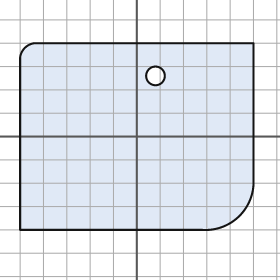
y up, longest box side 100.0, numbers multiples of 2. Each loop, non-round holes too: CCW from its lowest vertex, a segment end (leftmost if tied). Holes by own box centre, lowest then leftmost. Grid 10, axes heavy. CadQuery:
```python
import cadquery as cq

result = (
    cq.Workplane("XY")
    .moveTo(-50.0, -40.0)
    .lineTo(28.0, -40.0)
    .threePointArc((44.0, -34.0), (50.0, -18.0))
    .lineTo(50.0, 40.0)
    .lineTo(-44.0, 40.0)
    .threePointArc((-48.0, 38.0), (-50.0, 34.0))
    .close()
    .moveTo(8.0, 26.0)
    .circle(4.0)
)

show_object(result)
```